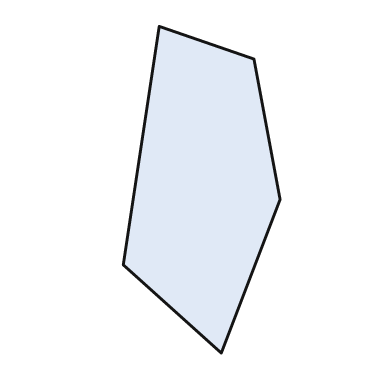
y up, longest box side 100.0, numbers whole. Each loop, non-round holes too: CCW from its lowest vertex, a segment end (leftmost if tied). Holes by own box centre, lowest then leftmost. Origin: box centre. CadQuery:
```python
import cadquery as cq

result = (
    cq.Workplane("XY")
    .moveTo(6.0, -50.0)
    .lineTo(24.0, -3.0)
    .lineTo(16.0, 40.0)
    .lineTo(-13.0, 50.0)
    .lineTo(-24.0, -23.0)
    .close()
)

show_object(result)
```